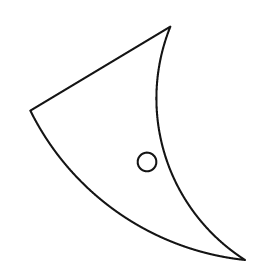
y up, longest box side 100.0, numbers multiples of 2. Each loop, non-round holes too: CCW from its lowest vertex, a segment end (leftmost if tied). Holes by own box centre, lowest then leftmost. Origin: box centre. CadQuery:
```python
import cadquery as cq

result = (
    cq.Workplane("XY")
    .moveTo(46.0, -50.0)
    .threePointArc((12.0, -6.0), (14.0, 50.0))
    .lineTo(-46.0, 14.0)
    .threePointArc((-8.0, -30.0), (46.0, -50.0))
    .close()
    .moveTo(4.0, -8.0)
    .circle(4.0)
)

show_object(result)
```